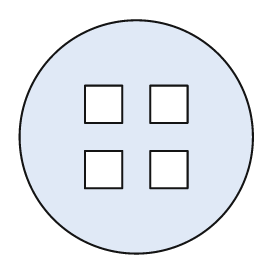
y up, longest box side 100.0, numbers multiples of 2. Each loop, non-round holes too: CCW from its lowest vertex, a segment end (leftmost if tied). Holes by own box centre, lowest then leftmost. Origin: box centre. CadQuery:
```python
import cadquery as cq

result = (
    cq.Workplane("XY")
    .moveTo(0.0, 0.0)
    .circle(50.0)
    .moveTo(-22.0, -22.0)
    .lineTo(-6.0, -22.0)
    .lineTo(-6.0, -6.0)
    .lineTo(-22.0, -6.0)
    .close()
    .moveTo(6.0, -22.0)
    .lineTo(22.0, -22.0)
    .lineTo(22.0, -6.0)
    .lineTo(6.0, -6.0)
    .close()
    .moveTo(-22.0, 6.0)
    .lineTo(-6.0, 6.0)
    .lineTo(-6.0, 22.0)
    .lineTo(-22.0, 22.0)
    .close()
    .moveTo(6.0, 6.0)
    .lineTo(22.0, 6.0)
    .lineTo(22.0, 22.0)
    .lineTo(6.0, 22.0)
    .close()
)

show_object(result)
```